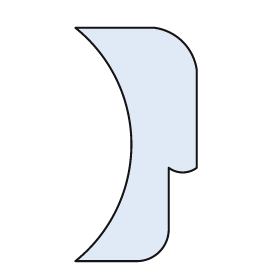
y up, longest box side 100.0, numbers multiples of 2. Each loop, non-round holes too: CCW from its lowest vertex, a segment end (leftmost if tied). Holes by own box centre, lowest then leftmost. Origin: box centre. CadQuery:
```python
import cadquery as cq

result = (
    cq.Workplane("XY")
    .moveTo(-26.0, -50.0)
    .lineTo(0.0, -50.0)
    .threePointArc((10.0, -46.0), (14.0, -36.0))
    .lineTo(14.0, -10.0)
    .threePointArc((20.0, -12.0), (26.0, -10.0))
    .lineTo(26.0, 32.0)
    .threePointArc((20.0, 44.0), (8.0, 50.0))
    .lineTo(-26.0, 50.0)
    .threePointArc((-2.0, 0.0), (-26.0, -50.0))
    .close()
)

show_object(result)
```